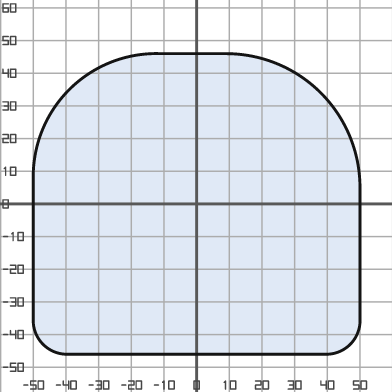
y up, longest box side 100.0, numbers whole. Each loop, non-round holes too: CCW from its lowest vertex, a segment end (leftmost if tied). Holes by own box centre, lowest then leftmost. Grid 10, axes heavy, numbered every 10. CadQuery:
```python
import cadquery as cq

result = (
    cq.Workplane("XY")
    .moveTo(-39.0, -46.0)
    .lineTo(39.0, -46.0)
    .threePointArc((47.0, -43.0), (50.0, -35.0))
    .lineTo(50.0, 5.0)
    .threePointArc((38.0, 34.0), (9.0, 46.0))
    .lineTo(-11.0, 46.0)
    .threePointArc((-39.0, 35.0), (-50.0, 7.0))
    .lineTo(-50.0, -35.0)
    .threePointArc((-47.0, -43.0), (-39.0, -46.0))
    .close()
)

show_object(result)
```